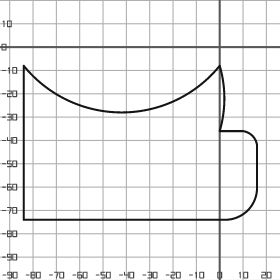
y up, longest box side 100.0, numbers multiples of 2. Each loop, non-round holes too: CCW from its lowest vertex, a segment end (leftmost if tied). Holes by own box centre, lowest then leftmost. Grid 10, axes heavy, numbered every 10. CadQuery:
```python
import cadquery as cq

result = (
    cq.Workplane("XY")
    .moveTo(-84.0, -74.0)
    .lineTo(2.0, -74.0)
    .threePointArc((12.0, -70.0), (16.0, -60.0))
    .lineTo(16.0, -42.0)
    .threePointArc((14.0, -38.0), (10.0, -36.0))
    .lineTo(0.0, -36.0)
    .threePointArc((2.0, -22.0), (0.0, -8.0))
    .threePointArc((-42.0, -28.0), (-84.0, -8.0))
    .close()
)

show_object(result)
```